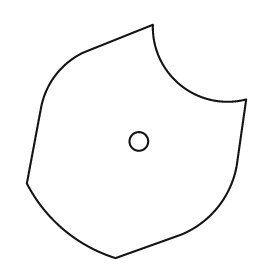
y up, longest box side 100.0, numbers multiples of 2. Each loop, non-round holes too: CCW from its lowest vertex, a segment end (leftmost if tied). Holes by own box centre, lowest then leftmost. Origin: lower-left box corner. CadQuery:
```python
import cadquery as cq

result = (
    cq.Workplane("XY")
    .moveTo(38.0, 0.0)
    .lineTo(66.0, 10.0)
    .threePointArc((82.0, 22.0), (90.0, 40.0))
    .lineTo(94.0, 68.0)
    .threePointArc((66.0, 74.0), (54.0, 100.0))
    .lineTo(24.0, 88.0)
    .threePointArc((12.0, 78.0), (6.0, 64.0))
    .lineTo(0.0, 32.0)
    .threePointArc((16.0, 12.0), (38.0, 0.0))
    .close()
    .moveTo(48.0, 50.0)
    .circle(4.0)
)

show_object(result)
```